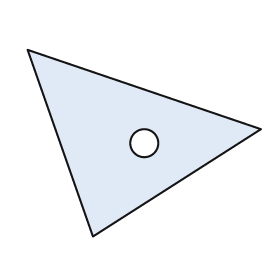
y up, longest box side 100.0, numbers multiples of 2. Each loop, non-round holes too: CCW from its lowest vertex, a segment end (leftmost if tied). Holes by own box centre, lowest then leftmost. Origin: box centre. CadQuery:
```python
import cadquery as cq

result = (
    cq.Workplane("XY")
    .moveTo(-22.0, -40.0)
    .lineTo(50.0, 6.0)
    .lineTo(-50.0, 40.0)
    .close()
    .moveTo(0.0, 0.0)
    .circle(6.0)
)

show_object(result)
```